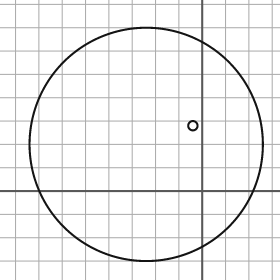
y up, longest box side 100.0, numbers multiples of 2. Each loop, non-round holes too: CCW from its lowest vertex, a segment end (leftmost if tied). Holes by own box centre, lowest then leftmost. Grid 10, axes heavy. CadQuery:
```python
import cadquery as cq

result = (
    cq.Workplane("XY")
    .moveTo(-24.0, 20.0)
    .circle(50.0)
    .moveTo(-4.0, 28.0)
    .circle(2.0)
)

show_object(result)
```